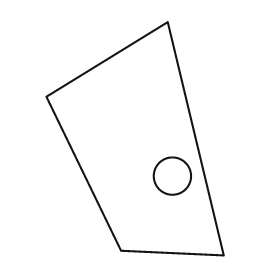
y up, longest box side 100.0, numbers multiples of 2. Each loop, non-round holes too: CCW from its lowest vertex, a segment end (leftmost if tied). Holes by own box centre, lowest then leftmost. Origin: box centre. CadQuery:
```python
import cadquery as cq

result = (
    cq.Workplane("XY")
    .moveTo(38.0, -50.0)
    .lineTo(14.0, 50.0)
    .lineTo(-38.0, 18.0)
    .lineTo(-6.0, -48.0)
    .close()
    .moveTo(16.0, -16.0)
    .circle(8.0)
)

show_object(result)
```